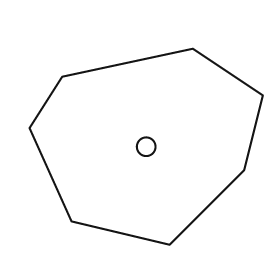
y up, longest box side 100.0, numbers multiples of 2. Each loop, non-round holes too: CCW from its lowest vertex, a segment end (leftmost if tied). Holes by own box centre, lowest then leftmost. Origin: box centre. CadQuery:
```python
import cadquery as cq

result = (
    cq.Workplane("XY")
    .moveTo(10.0, -42.0)
    .lineTo(42.0, -10.0)
    .lineTo(50.0, 22.0)
    .lineTo(20.0, 42.0)
    .lineTo(-36.0, 30.0)
    .lineTo(-50.0, 8.0)
    .lineTo(-32.0, -32.0)
    .close()
    .moveTo(0.0, 0.0)
    .circle(4.0)
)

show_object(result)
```